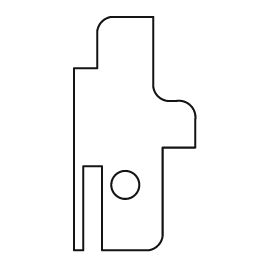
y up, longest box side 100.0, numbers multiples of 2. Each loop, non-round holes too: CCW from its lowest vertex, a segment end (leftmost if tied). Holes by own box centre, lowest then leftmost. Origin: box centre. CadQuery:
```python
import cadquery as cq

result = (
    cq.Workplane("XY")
    .moveTo(-26.0, -50.0)
    .lineTo(-22.0, -50.0)
    .lineTo(-22.0, -14.0)
    .lineTo(-14.0, -14.0)
    .lineTo(-14.0, -50.0)
    .lineTo(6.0, -50.0)
    .threePointArc((10.0, -48.0), (12.0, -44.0))
    .lineTo(12.0, -6.0)
    .lineTo(26.0, -6.0)
    .lineTo(26.0, 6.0)
    .threePointArc((24.0, 12.0), (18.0, 14.0))
    .lineTo(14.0, 14.0)
    .threePointArc((10.0, 16.0), (8.0, 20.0))
    .lineTo(8.0, 50.0)
    .lineTo(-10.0, 50.0)
    .threePointArc((-14.0, 48.0), (-16.0, 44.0))
    .lineTo(-16.0, 28.0)
    .lineTo(-26.0, 28.0)
    .close()
    .moveTo(-4.0, -22.0)
    .circle(6.0)
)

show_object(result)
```